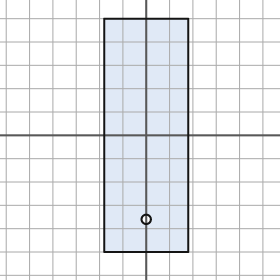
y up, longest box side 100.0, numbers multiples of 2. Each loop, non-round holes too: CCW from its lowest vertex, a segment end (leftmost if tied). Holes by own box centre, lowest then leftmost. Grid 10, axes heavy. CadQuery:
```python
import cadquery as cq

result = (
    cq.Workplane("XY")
    .moveTo(-18.0, -50.0)
    .lineTo(18.0, -50.0)
    .lineTo(18.0, 50.0)
    .lineTo(-18.0, 50.0)
    .close()
    .moveTo(0.0, -36.0)
    .circle(2.0)
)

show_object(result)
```